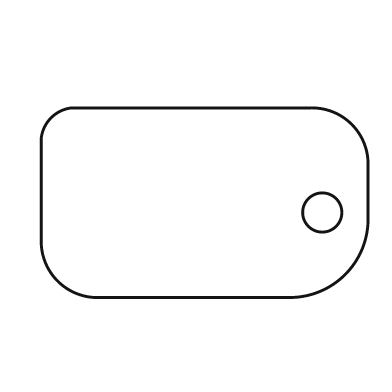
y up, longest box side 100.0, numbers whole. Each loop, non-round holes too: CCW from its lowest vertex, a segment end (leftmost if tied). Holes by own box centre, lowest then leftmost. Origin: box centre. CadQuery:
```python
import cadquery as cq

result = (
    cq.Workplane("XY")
    .moveTo(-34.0, -29.0)
    .lineTo(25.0, -29.0)
    .threePointArc((43.0, -22.0), (50.0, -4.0))
    .lineTo(50.0, 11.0)
    .threePointArc((45.0, 24.0), (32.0, 29.0))
    .lineTo(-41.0, 29.0)
    .threePointArc((-47.0, 26.0), (-50.0, 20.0))
    .lineTo(-50.0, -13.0)
    .threePointArc((-45.0, -24.0), (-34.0, -29.0))
    .close()
    .moveTo(36.0, -3.0)
    .circle(6.0)
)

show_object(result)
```